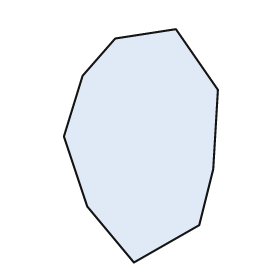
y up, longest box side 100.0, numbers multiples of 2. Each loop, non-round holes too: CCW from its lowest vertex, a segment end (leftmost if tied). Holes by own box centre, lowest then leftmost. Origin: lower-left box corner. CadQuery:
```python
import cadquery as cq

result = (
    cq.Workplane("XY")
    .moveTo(30.0, 0.0)
    .lineTo(58.0, 16.0)
    .lineTo(64.0, 40.0)
    .lineTo(66.0, 74.0)
    .lineTo(48.0, 100.0)
    .lineTo(22.0, 96.0)
    .lineTo(8.0, 80.0)
    .lineTo(0.0, 54.0)
    .lineTo(10.0, 24.0)
    .close()
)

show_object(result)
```